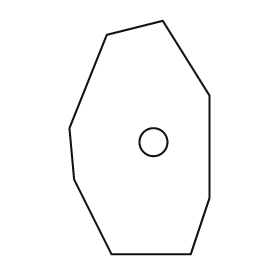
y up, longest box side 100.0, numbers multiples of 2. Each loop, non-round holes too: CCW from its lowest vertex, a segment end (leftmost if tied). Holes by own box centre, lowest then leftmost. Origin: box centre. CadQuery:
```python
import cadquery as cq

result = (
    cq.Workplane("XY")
    .moveTo(-12.0, -50.0)
    .lineTo(22.0, -50.0)
    .lineTo(30.0, -26.0)
    .lineTo(30.0, 18.0)
    .lineTo(10.0, 50.0)
    .lineTo(-14.0, 44.0)
    .lineTo(-30.0, 4.0)
    .lineTo(-28.0, -18.0)
    .close()
    .moveTo(6.0, -2.0)
    .circle(6.0)
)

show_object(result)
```